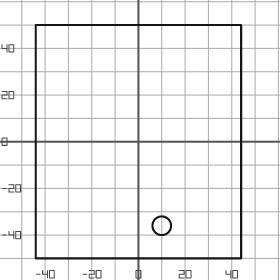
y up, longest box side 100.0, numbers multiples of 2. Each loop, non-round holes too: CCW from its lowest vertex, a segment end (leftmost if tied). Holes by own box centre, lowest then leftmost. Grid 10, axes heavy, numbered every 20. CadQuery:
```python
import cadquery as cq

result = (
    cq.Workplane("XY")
    .moveTo(-44.0, -50.0)
    .lineTo(44.0, -50.0)
    .lineTo(44.0, 50.0)
    .lineTo(-44.0, 50.0)
    .close()
    .moveTo(10.0, -36.0)
    .circle(4.0)
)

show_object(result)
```